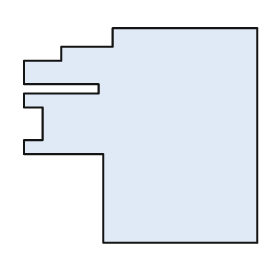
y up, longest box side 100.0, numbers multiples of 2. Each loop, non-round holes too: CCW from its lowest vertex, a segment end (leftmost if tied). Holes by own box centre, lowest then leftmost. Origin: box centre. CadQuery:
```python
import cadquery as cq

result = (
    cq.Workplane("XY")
    .moveTo(-16.0, -46.0)
    .lineTo(50.0, -46.0)
    .lineTo(50.0, 46.0)
    .lineTo(-12.0, 46.0)
    .lineTo(-12.0, 38.0)
    .lineTo(-34.0, 38.0)
    .lineTo(-34.0, 32.0)
    .lineTo(-50.0, 32.0)
    .lineTo(-50.0, 22.0)
    .lineTo(-18.0, 22.0)
    .lineTo(-18.0, 18.0)
    .lineTo(-50.0, 18.0)
    .lineTo(-50.0, 12.0)
    .lineTo(-42.0, 12.0)
    .lineTo(-42.0, -2.0)
    .lineTo(-50.0, -2.0)
    .lineTo(-50.0, -8.0)
    .lineTo(-16.0, -8.0)
    .close()
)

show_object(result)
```